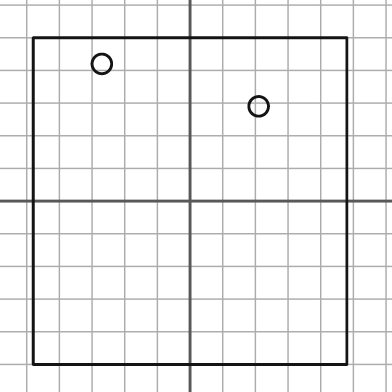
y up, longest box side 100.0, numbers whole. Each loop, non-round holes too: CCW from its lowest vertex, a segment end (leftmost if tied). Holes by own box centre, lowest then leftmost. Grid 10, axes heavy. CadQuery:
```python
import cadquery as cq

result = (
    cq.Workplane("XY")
    .moveTo(-48.0, -50.0)
    .lineTo(48.0, -50.0)
    .lineTo(48.0, 50.0)
    .lineTo(-48.0, 50.0)
    .close()
    .moveTo(21.0, 29.0)
    .circle(3.0)
    .moveTo(-27.0, 42.0)
    .circle(3.0)
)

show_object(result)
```